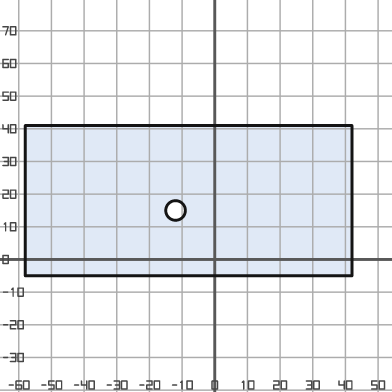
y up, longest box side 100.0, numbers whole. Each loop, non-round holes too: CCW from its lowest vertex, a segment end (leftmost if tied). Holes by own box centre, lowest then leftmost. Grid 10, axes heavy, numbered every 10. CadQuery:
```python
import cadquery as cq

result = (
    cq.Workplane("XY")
    .moveTo(-58.0, -5.0)
    .lineTo(42.0, -5.0)
    .lineTo(42.0, 41.0)
    .lineTo(-58.0, 41.0)
    .close()
    .moveTo(-12.0, 15.0)
    .circle(3.0)
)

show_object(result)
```